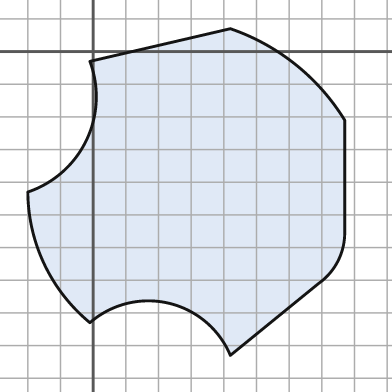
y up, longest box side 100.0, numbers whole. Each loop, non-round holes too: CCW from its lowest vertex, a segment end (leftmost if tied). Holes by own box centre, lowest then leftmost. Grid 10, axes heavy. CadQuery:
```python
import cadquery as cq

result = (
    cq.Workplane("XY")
    .moveTo(42.0, -93.0)
    .lineTo(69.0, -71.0)
    .threePointArc((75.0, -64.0), (77.0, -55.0))
    .lineTo(77.0, -21.0)
    .threePointArc((62.0, -4.0), (42.0, 7.0))
    .lineTo(-1.0, -3.0)
    .threePointArc((-2.0, -27.0), (-20.0, -43.0))
    .threePointArc((-15.0, -65.0), (-1.0, -83.0))
    .threePointArc((23.0, -77.0), (42.0, -93.0))
    .close()
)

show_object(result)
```